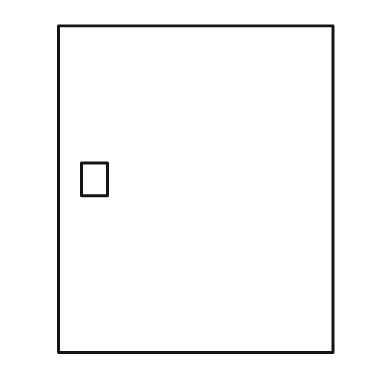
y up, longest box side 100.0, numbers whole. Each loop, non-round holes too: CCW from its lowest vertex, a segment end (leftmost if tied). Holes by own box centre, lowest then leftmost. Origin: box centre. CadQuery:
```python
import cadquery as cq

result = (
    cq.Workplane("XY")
    .moveTo(-42.0, -50.0)
    .lineTo(42.0, -50.0)
    .lineTo(42.0, 50.0)
    .lineTo(-42.0, 50.0)
    .close()
    .moveTo(-35.0, -2.0)
    .lineTo(-27.0, -2.0)
    .lineTo(-27.0, 8.0)
    .lineTo(-35.0, 8.0)
    .close()
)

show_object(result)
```